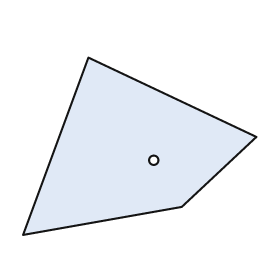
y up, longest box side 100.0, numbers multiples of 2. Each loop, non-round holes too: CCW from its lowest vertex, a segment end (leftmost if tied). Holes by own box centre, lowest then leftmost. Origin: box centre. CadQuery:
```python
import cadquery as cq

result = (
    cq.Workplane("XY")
    .moveTo(-50.0, -38.0)
    .lineTo(18.0, -26.0)
    .lineTo(50.0, 4.0)
    .lineTo(-22.0, 38.0)
    .close()
    .moveTo(6.0, -6.0)
    .circle(2.0)
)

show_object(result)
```